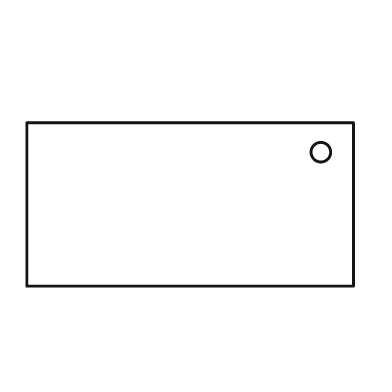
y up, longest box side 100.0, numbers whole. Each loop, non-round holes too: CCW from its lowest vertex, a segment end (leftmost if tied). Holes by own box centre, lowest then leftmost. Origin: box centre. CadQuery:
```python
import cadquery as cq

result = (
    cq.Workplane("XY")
    .moveTo(-50.0, -25.0)
    .lineTo(50.0, -25.0)
    .lineTo(50.0, 25.0)
    .lineTo(-50.0, 25.0)
    .close()
    .moveTo(40.0, 16.0)
    .circle(3.0)
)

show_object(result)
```